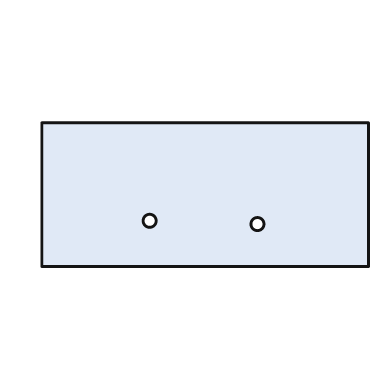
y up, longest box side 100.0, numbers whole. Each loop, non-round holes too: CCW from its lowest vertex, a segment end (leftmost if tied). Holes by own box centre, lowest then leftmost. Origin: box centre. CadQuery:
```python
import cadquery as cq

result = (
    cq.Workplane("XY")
    .moveTo(-50.0, -22.0)
    .lineTo(50.0, -22.0)
    .lineTo(50.0, 22.0)
    .lineTo(-50.0, 22.0)
    .close()
    .moveTo(16.0, -9.0)
    .circle(2.0)
    .moveTo(-17.0, -8.0)
    .circle(2.0)
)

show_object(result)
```